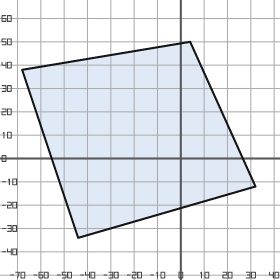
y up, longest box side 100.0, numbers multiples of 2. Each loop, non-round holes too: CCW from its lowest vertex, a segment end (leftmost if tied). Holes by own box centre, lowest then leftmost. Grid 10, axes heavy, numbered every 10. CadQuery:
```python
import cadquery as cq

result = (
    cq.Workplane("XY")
    .moveTo(-44.0, -34.0)
    .lineTo(32.0, -12.0)
    .lineTo(4.0, 50.0)
    .lineTo(-68.0, 38.0)
    .close()
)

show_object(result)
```